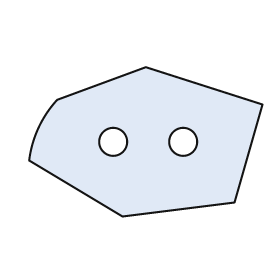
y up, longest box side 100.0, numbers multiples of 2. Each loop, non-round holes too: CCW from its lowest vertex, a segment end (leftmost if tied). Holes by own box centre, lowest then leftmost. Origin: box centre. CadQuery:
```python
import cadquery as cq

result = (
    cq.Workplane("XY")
    .moveTo(-10.0, -32.0)
    .lineTo(38.0, -26.0)
    .lineTo(50.0, 16.0)
    .lineTo(0.0, 32.0)
    .lineTo(-38.0, 18.0)
    .threePointArc((-46.0, 6.0), (-50.0, -8.0))
    .close()
    .moveTo(-14.0, 0.0)
    .circle(6.0)
    .moveTo(16.0, 0.0)
    .circle(6.0)
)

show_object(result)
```